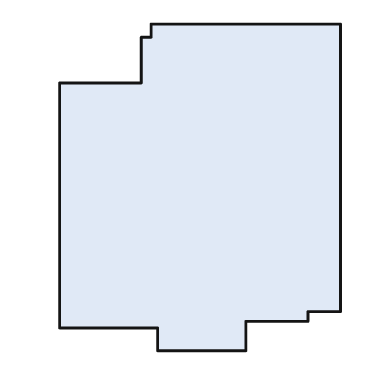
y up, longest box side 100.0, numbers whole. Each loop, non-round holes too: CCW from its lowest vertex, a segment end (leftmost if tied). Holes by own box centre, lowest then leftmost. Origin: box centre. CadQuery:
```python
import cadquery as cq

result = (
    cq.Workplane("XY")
    .moveTo(-13.0, -50.0)
    .lineTo(14.0, -50.0)
    .lineTo(14.0, -41.0)
    .lineTo(33.0, -41.0)
    .lineTo(33.0, -38.0)
    .lineTo(43.0, -38.0)
    .lineTo(43.0, 50.0)
    .lineTo(-15.0, 50.0)
    .lineTo(-15.0, 46.0)
    .lineTo(-18.0, 46.0)
    .lineTo(-18.0, 32.0)
    .lineTo(-43.0, 32.0)
    .lineTo(-43.0, -43.0)
    .lineTo(-13.0, -43.0)
    .close()
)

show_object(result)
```